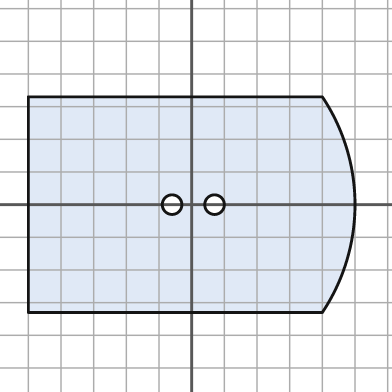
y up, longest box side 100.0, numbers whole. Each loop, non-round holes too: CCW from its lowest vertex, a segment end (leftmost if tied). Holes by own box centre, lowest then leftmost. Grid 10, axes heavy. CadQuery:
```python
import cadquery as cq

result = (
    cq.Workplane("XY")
    .moveTo(-50.0, -33.0)
    .lineTo(40.0, -33.0)
    .threePointArc((50.0, 0.0), (40.0, 33.0))
    .lineTo(-50.0, 33.0)
    .close()
    .moveTo(-6.0, 0.0)
    .circle(3.0)
    .moveTo(7.0, 0.0)
    .circle(3.0)
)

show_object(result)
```